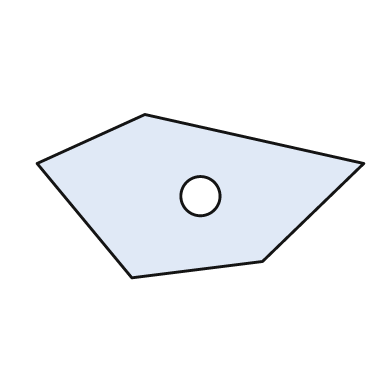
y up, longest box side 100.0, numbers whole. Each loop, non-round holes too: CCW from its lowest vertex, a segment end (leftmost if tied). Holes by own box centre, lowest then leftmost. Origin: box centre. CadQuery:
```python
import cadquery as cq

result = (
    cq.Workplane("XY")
    .moveTo(-21.0, -25.0)
    .lineTo(19.0, -20.0)
    .lineTo(50.0, 10.0)
    .lineTo(-17.0, 25.0)
    .lineTo(-50.0, 10.0)
    .close()
    .moveTo(0.0, 0.0)
    .circle(6.0)
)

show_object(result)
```